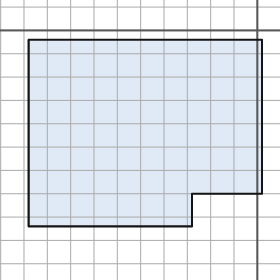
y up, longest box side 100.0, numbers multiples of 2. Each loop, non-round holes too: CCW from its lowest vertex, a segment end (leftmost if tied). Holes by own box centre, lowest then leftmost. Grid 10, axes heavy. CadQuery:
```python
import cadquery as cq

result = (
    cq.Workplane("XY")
    .moveTo(-98.0, -84.0)
    .lineTo(-28.0, -84.0)
    .lineTo(-28.0, -70.0)
    .lineTo(2.0, -70.0)
    .lineTo(2.0, -4.0)
    .lineTo(-98.0, -4.0)
    .close()
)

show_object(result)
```